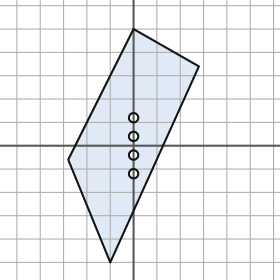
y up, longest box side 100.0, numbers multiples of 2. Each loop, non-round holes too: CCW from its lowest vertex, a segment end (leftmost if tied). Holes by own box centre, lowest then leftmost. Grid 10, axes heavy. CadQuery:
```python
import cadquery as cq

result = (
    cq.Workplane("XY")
    .moveTo(-10.0, -50.0)
    .lineTo(28.0, 34.0)
    .lineTo(0.0, 50.0)
    .lineTo(-28.0, -6.0)
    .close()
    .moveTo(0.0, -12.0)
    .circle(2.0)
    .moveTo(0.0, -4.0)
    .circle(2.0)
    .moveTo(0.0, 4.0)
    .circle(2.0)
    .moveTo(0.0, 12.0)
    .circle(2.0)
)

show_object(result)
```